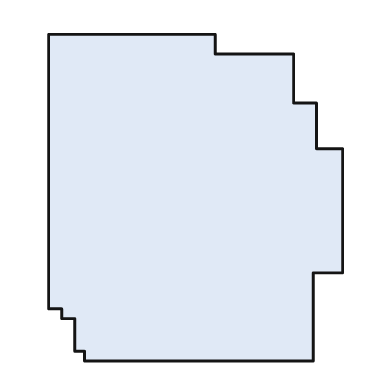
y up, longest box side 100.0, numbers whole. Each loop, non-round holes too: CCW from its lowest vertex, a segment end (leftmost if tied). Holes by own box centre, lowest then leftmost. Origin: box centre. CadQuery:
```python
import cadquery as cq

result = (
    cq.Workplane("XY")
    .moveTo(-34.0, -50.0)
    .lineTo(36.0, -50.0)
    .lineTo(36.0, -23.0)
    .lineTo(45.0, -23.0)
    .lineTo(45.0, 15.0)
    .lineTo(37.0, 15.0)
    .lineTo(37.0, 29.0)
    .lineTo(30.0, 29.0)
    .lineTo(30.0, 44.0)
    .lineTo(6.0, 44.0)
    .lineTo(6.0, 50.0)
    .lineTo(-45.0, 50.0)
    .lineTo(-45.0, -34.0)
    .lineTo(-41.0, -34.0)
    .lineTo(-41.0, -37.0)
    .lineTo(-37.0, -37.0)
    .lineTo(-37.0, -47.0)
    .lineTo(-34.0, -47.0)
    .close()
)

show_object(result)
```